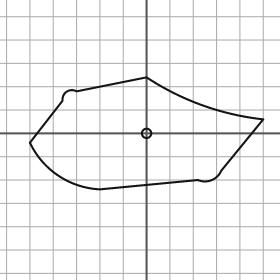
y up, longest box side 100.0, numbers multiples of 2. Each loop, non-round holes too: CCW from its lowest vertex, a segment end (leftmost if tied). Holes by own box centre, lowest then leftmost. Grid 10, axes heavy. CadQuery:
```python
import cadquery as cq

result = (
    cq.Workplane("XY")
    .moveTo(-20.0, -24.0)
    .lineTo(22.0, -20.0)
    .threePointArc((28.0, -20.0), (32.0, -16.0))
    .lineTo(50.0, 6.0)
    .threePointArc((24.0, 12.0), (0.0, 24.0))
    .lineTo(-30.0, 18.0)
    .threePointArc((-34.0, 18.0), (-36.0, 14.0))
    .lineTo(-50.0, -4.0)
    .threePointArc((-38.0, -18.0), (-20.0, -24.0))
    .close()
    .moveTo(0.0, 0.0)
    .circle(2.0)
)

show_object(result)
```